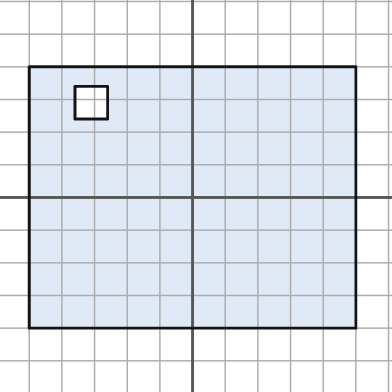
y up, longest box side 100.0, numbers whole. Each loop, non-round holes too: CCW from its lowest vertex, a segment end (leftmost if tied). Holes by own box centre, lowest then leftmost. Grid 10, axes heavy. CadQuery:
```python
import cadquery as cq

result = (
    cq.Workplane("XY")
    .moveTo(-50.0, -40.0)
    .lineTo(50.0, -40.0)
    .lineTo(50.0, 40.0)
    .lineTo(-50.0, 40.0)
    .close()
    .moveTo(-36.0, 24.0)
    .lineTo(-26.0, 24.0)
    .lineTo(-26.0, 34.0)
    .lineTo(-36.0, 34.0)
    .close()
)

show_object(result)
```